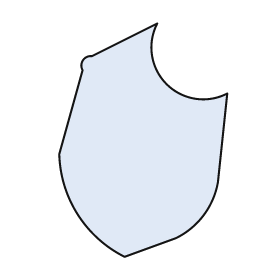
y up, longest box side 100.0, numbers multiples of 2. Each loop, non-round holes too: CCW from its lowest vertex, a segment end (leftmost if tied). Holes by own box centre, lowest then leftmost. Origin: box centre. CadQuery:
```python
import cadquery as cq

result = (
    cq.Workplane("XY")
    .moveTo(-8.0, -50.0)
    .lineTo(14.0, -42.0)
    .threePointArc((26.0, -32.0), (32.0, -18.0))
    .lineTo(36.0, 20.0)
    .threePointArc((10.0, 24.0), (6.0, 50.0))
    .lineTo(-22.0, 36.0)
    .threePointArc((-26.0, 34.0), (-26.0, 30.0))
    .lineTo(-36.0, -6.0)
    .threePointArc((-28.0, -32.0), (-8.0, -50.0))
    .close()
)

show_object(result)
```